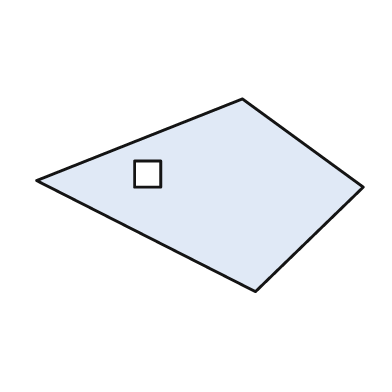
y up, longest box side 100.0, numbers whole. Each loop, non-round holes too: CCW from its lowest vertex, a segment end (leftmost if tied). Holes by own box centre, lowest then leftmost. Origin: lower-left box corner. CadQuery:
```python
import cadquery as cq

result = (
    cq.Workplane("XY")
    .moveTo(67.0, 0.0)
    .lineTo(100.0, 32.0)
    .lineTo(63.0, 59.0)
    .lineTo(0.0, 34.0)
    .close()
    .moveTo(30.0, 32.0)
    .lineTo(38.0, 32.0)
    .lineTo(38.0, 40.0)
    .lineTo(30.0, 40.0)
    .close()
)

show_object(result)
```